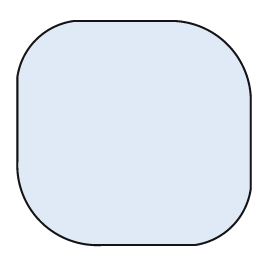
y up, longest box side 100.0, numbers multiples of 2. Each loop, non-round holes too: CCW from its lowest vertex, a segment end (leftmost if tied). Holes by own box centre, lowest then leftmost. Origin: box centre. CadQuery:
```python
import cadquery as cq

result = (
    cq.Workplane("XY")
    .moveTo(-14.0, -48.0)
    .lineTo(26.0, -48.0)
    .threePointArc((42.0, -40.0), (50.0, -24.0))
    .lineTo(50.0, 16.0)
    .threePointArc((40.0, 38.0), (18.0, 48.0))
    .lineTo(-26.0, 48.0)
    .threePointArc((-42.0, 40.0), (-50.0, 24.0))
    .lineTo(-50.0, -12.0)
    .threePointArc((-40.0, -38.0), (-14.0, -48.0))
    .close()
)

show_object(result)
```